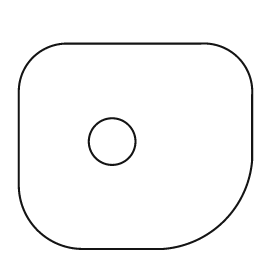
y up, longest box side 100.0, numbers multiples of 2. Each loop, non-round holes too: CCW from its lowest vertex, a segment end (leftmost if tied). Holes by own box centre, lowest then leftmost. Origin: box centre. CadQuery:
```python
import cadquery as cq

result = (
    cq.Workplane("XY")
    .moveTo(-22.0, -44.0)
    .lineTo(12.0, -44.0)
    .threePointArc((38.0, -32.0), (50.0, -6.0))
    .lineTo(50.0, 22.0)
    .threePointArc((44.0, 38.0), (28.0, 44.0))
    .lineTo(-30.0, 44.0)
    .threePointArc((-44.0, 38.0), (-50.0, 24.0))
    .lineTo(-50.0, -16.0)
    .threePointArc((-42.0, -36.0), (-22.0, -44.0))
    .close()
    .moveTo(-10.0, 2.0)
    .circle(10.0)
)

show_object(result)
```